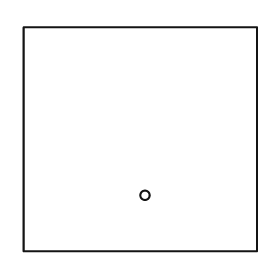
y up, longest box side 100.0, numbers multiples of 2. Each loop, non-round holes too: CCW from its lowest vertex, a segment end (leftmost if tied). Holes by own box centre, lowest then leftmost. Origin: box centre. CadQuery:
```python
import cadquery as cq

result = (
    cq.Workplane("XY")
    .moveTo(-50.0, -48.0)
    .lineTo(50.0, -48.0)
    .lineTo(50.0, 48.0)
    .lineTo(-50.0, 48.0)
    .close()
    .moveTo(2.0, -24.0)
    .circle(2.0)
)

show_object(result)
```